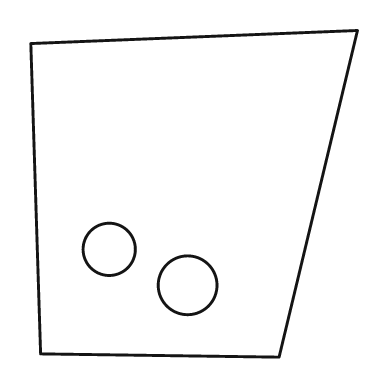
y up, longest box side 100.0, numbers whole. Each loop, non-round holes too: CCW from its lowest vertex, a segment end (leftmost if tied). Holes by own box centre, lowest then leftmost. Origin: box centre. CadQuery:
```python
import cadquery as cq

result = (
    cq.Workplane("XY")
    .moveTo(26.0, -50.0)
    .lineTo(50.0, 50.0)
    .lineTo(-50.0, 46.0)
    .lineTo(-47.0, -49.0)
    .close()
    .moveTo(-2.0, -28.0)
    .circle(9.0)
    .moveTo(-26.0, -17.0)
    .circle(8.0)
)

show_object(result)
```